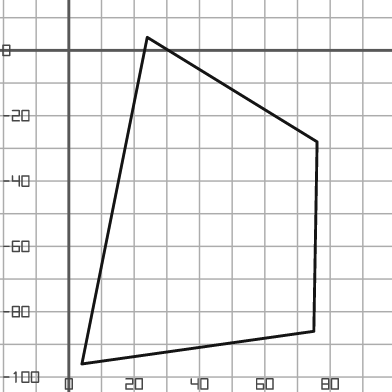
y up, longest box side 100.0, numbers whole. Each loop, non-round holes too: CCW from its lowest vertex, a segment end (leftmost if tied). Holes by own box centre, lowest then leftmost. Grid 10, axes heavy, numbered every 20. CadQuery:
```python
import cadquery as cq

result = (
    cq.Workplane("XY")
    .moveTo(4.0, -96.0)
    .lineTo(75.0, -86.0)
    .lineTo(76.0, -28.0)
    .lineTo(24.0, 4.0)
    .close()
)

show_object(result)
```